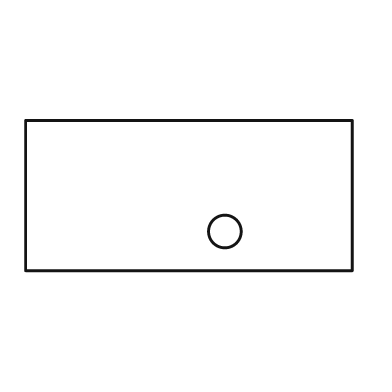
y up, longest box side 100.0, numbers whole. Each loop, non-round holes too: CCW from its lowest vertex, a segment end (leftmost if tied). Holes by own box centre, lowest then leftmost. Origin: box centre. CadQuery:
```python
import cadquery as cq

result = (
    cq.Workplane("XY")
    .moveTo(-50.0, -23.0)
    .lineTo(50.0, -23.0)
    .lineTo(50.0, 23.0)
    .lineTo(-50.0, 23.0)
    .close()
    .moveTo(11.0, -11.0)
    .circle(5.0)
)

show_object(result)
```